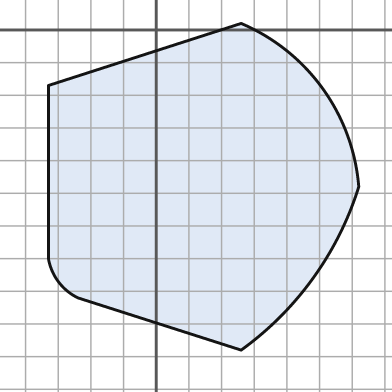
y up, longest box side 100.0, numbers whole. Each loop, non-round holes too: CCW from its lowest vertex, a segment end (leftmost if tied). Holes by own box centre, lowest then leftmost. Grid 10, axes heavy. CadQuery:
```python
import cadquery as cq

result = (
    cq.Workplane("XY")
    .moveTo(26.0, -98.0)
    .threePointArc((48.0, -76.0), (62.0, -48.0))
    .threePointArc((51.0, -18.0), (26.0, 2.0))
    .lineTo(-33.0, -17.0)
    .lineTo(-33.0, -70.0)
    .threePointArc((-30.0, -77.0), (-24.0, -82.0))
    .close()
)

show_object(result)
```